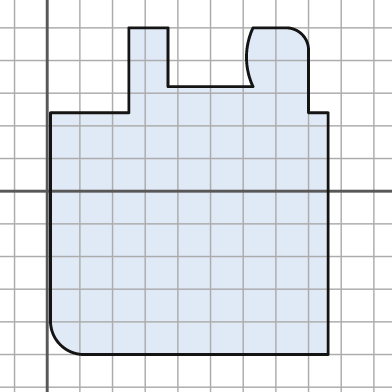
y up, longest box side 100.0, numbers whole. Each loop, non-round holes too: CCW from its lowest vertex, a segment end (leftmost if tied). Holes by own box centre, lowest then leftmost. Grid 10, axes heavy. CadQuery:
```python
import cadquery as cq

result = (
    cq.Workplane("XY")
    .moveTo(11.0, -50.0)
    .lineTo(86.0, -50.0)
    .lineTo(86.0, 24.0)
    .lineTo(80.0, 24.0)
    .lineTo(80.0, 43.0)
    .threePointArc((78.0, 48.0), (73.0, 50.0))
    .lineTo(63.0, 50.0)
    .threePointArc((61.0, 41.0), (63.0, 32.0))
    .lineTo(37.0, 32.0)
    .lineTo(37.0, 50.0)
    .lineTo(25.0, 50.0)
    .lineTo(25.0, 24.0)
    .lineTo(1.0, 24.0)
    .lineTo(1.0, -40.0)
    .threePointArc((4.0, -47.0), (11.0, -50.0))
    .close()
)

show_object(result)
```